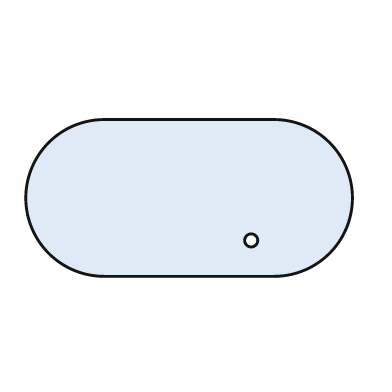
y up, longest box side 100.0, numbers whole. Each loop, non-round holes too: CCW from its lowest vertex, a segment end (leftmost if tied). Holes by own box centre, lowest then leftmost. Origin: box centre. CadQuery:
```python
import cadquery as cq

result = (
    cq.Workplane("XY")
    .moveTo(-26.0, -24.0)
    .lineTo(26.0, -24.0)
    .threePointArc((50.0, 0.0), (26.0, 24.0))
    .lineTo(-26.0, 24.0)
    .threePointArc((-50.0, 0.0), (-26.0, -24.0))
    .close()
    .moveTo(19.0, -13.0)
    .circle(2.0)
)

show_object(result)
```